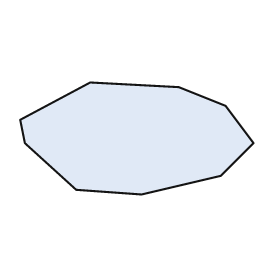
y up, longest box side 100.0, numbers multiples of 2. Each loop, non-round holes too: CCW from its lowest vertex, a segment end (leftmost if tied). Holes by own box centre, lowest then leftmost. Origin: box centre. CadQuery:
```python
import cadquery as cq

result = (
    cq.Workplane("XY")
    .moveTo(2.0, -24.0)
    .lineTo(36.0, -16.0)
    .lineTo(50.0, -2.0)
    .lineTo(38.0, 14.0)
    .lineTo(18.0, 22.0)
    .lineTo(-20.0, 24.0)
    .lineTo(-50.0, 8.0)
    .lineTo(-48.0, -2.0)
    .lineTo(-26.0, -22.0)
    .close()
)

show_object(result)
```